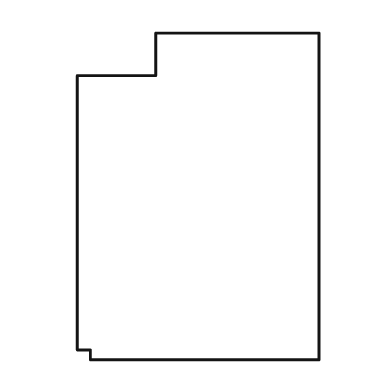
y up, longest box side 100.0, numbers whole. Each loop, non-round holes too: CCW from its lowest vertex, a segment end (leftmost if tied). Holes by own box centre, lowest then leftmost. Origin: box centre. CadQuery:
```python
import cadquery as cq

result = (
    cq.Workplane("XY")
    .moveTo(-33.0, -50.0)
    .lineTo(37.0, -50.0)
    .lineTo(37.0, 50.0)
    .lineTo(-13.0, 50.0)
    .lineTo(-13.0, 37.0)
    .lineTo(-37.0, 37.0)
    .lineTo(-37.0, -47.0)
    .lineTo(-33.0, -47.0)
    .close()
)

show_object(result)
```